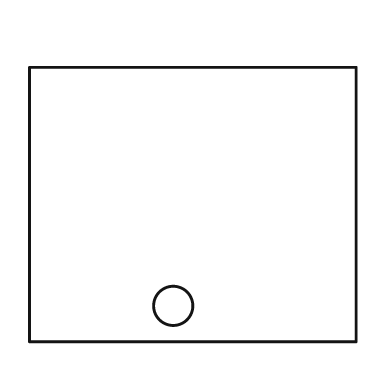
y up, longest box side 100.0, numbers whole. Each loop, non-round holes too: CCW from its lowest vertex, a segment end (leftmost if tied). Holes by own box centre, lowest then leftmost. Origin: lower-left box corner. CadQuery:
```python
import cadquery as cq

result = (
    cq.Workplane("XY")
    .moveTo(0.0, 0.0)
    .lineTo(100.0, 0.0)
    .lineTo(100.0, 84.0)
    .lineTo(0.0, 84.0)
    .close()
    .moveTo(44.0, 11.0)
    .circle(6.0)
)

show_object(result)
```